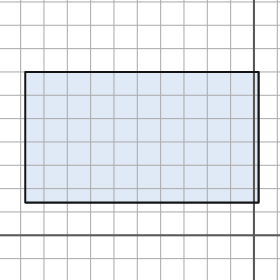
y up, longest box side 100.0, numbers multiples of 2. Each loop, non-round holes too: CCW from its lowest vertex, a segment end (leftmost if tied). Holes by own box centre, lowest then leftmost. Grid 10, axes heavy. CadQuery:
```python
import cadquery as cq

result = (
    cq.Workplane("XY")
    .moveTo(-98.0, 14.0)
    .lineTo(2.0, 14.0)
    .lineTo(2.0, 70.0)
    .lineTo(-98.0, 70.0)
    .close()
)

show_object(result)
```